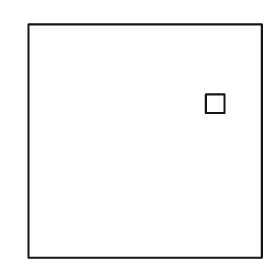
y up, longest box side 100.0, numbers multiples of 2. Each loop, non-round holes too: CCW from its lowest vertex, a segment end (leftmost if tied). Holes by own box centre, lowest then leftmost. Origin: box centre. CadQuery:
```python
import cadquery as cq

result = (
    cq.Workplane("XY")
    .moveTo(-50.0, -50.0)
    .lineTo(50.0, -50.0)
    .lineTo(50.0, 50.0)
    .lineTo(-50.0, 50.0)
    .close()
    .moveTo(26.0, 12.0)
    .lineTo(34.0, 12.0)
    .lineTo(34.0, 20.0)
    .lineTo(26.0, 20.0)
    .close()
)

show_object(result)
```